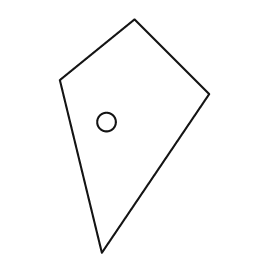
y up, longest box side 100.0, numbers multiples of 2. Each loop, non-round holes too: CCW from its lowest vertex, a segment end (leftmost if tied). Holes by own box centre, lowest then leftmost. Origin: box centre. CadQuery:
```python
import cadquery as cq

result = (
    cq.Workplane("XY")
    .moveTo(-14.0, -50.0)
    .lineTo(32.0, 18.0)
    .lineTo(0.0, 50.0)
    .lineTo(-32.0, 24.0)
    .close()
    .moveTo(-12.0, 6.0)
    .circle(4.0)
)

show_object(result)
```